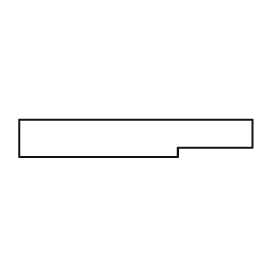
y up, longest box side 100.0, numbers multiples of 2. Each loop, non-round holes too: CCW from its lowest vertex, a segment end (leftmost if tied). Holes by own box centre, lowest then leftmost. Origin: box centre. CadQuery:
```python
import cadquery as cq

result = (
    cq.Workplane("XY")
    .moveTo(-50.0, -8.0)
    .lineTo(18.0, -8.0)
    .lineTo(18.0, -4.0)
    .lineTo(50.0, -4.0)
    .lineTo(50.0, 8.0)
    .lineTo(-50.0, 8.0)
    .close()
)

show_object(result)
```